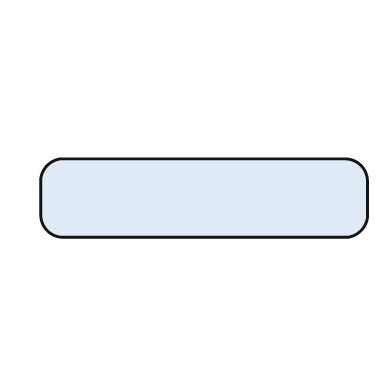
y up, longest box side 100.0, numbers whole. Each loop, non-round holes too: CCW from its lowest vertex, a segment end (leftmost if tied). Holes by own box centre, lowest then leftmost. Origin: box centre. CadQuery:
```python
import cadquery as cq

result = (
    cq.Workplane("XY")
    .moveTo(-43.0, -12.0)
    .lineTo(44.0, -12.0)
    .threePointArc((48.0, -10.0), (50.0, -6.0))
    .lineTo(50.0, 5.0)
    .threePointArc((48.0, 10.0), (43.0, 12.0))
    .lineTo(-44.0, 12.0)
    .threePointArc((-48.0, 10.0), (-50.0, 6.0))
    .lineTo(-50.0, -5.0)
    .threePointArc((-48.0, -10.0), (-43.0, -12.0))
    .close()
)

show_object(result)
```